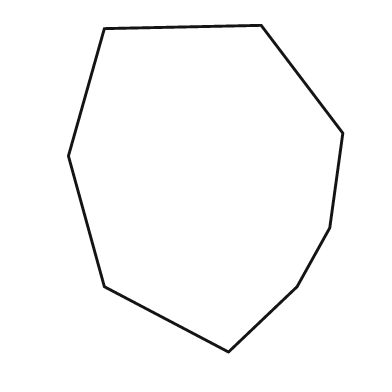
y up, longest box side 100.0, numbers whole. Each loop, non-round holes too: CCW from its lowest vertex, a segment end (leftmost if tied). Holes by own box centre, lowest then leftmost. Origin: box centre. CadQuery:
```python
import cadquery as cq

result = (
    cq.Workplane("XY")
    .moveTo(7.0, -50.0)
    .lineTo(28.0, -30.0)
    .lineTo(38.0, -12.0)
    .lineTo(42.0, 17.0)
    .lineTo(17.0, 50.0)
    .lineTo(-31.0, 49.0)
    .lineTo(-42.0, 10.0)
    .lineTo(-31.0, -30.0)
    .close()
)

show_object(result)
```